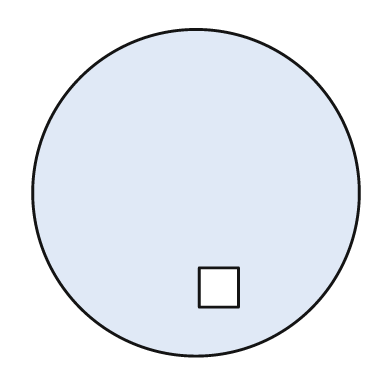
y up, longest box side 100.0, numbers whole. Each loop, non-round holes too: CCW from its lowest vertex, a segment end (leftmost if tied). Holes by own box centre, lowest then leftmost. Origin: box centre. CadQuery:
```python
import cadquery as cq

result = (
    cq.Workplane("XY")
    .moveTo(0.0, 0.0)
    .circle(50.0)
    .moveTo(1.0, -35.0)
    .lineTo(13.0, -35.0)
    .lineTo(13.0, -23.0)
    .lineTo(1.0, -23.0)
    .close()
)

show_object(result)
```